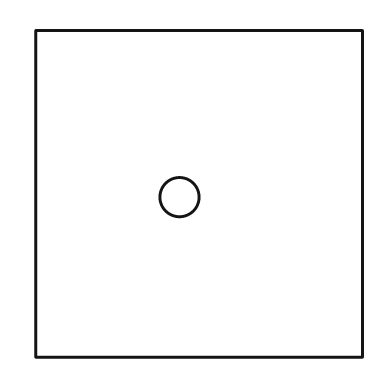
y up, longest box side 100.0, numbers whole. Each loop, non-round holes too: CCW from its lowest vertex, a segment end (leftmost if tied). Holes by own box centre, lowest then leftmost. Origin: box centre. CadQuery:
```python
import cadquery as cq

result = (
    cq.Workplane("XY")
    .moveTo(-50.0, -50.0)
    .lineTo(50.0, -50.0)
    .lineTo(50.0, 50.0)
    .lineTo(-50.0, 50.0)
    .close()
    .moveTo(-6.0, -1.0)
    .circle(6.0)
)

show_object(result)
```